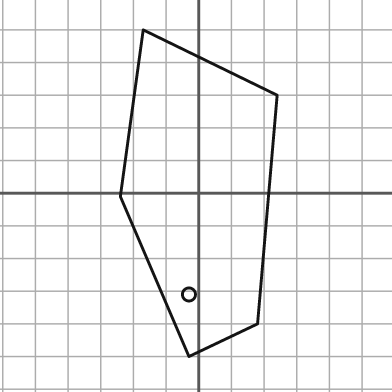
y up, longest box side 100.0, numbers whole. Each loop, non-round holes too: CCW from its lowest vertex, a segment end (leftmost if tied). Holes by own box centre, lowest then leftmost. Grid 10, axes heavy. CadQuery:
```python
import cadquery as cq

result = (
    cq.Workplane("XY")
    .moveTo(-3.0, -50.0)
    .lineTo(18.0, -40.0)
    .lineTo(24.0, 30.0)
    .lineTo(-17.0, 50.0)
    .lineTo(-24.0, -1.0)
    .close()
    .moveTo(-3.0, -31.0)
    .circle(2.0)
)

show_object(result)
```